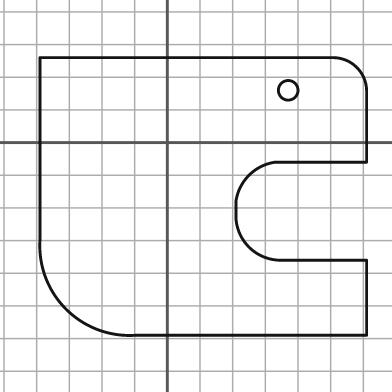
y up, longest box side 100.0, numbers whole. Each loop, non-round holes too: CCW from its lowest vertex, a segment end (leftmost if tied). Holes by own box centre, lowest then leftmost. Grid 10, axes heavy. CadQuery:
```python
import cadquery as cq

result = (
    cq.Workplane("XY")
    .moveTo(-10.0, -59.0)
    .lineTo(61.0, -59.0)
    .lineTo(61.0, -36.0)
    .lineTo(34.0, -36.0)
    .threePointArc((25.0, -32.0), (21.0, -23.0))
    .lineTo(21.0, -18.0)
    .threePointArc((25.0, -10.0), (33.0, -6.0))
    .lineTo(61.0, -6.0)
    .lineTo(61.0, 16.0)
    .threePointArc((58.0, 23.0), (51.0, 26.0))
    .lineTo(-39.0, 26.0)
    .lineTo(-39.0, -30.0)
    .threePointArc((-31.0, -51.0), (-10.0, -59.0))
    .close()
    .moveTo(37.0, 16.0)
    .circle(3.0)
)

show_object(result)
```